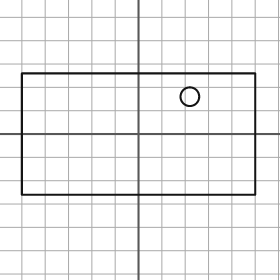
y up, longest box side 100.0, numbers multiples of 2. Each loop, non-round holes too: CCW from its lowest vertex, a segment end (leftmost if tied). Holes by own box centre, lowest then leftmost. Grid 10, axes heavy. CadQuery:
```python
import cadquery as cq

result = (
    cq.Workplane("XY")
    .moveTo(-50.0, -26.0)
    .lineTo(50.0, -26.0)
    .lineTo(50.0, 26.0)
    .lineTo(-50.0, 26.0)
    .close()
    .moveTo(22.0, 16.0)
    .circle(4.0)
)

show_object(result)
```